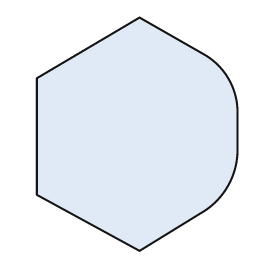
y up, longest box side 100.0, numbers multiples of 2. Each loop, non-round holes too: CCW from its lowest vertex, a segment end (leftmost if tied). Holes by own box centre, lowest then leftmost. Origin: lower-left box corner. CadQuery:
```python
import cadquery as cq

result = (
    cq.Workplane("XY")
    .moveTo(44.0, 0.0)
    .lineTo(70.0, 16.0)
    .threePointArc((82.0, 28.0), (86.0, 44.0))
    .lineTo(86.0, 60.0)
    .threePointArc((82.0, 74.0), (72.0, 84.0))
    .lineTo(44.0, 100.0)
    .lineTo(0.0, 74.0)
    .lineTo(0.0, 24.0)
    .close()
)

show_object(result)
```